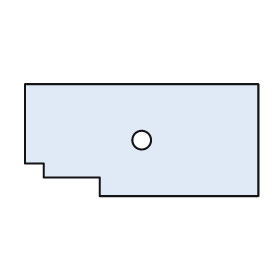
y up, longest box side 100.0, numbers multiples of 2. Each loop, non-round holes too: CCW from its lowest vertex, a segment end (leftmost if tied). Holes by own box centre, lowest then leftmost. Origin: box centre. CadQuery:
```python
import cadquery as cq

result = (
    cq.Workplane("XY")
    .moveTo(-18.0, -24.0)
    .lineTo(50.0, -24.0)
    .lineTo(50.0, 24.0)
    .lineTo(-50.0, 24.0)
    .lineTo(-50.0, -10.0)
    .lineTo(-42.0, -10.0)
    .lineTo(-42.0, -16.0)
    .lineTo(-18.0, -16.0)
    .close()
    .moveTo(0.0, 0.0)
    .circle(4.0)
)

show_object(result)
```